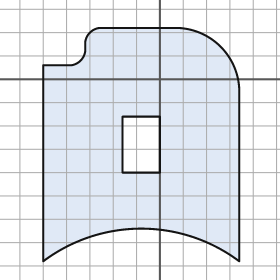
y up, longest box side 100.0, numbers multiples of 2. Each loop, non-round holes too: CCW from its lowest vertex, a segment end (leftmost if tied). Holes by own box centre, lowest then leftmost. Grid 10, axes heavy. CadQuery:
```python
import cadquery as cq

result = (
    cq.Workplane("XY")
    .moveTo(-50.0, -78.0)
    .threePointArc((-8.0, -64.0), (34.0, -78.0))
    .lineTo(34.0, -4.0)
    .threePointArc((26.0, 14.0), (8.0, 22.0))
    .lineTo(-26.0, 22.0)
    .threePointArc((-30.0, 20.0), (-32.0, 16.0))
    .lineTo(-32.0, 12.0)
    .threePointArc((-34.0, 8.0), (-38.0, 6.0))
    .lineTo(-50.0, 6.0)
    .close()
    .moveTo(-16.0, -40.0)
    .lineTo(0.0, -40.0)
    .lineTo(0.0, -16.0)
    .lineTo(-16.0, -16.0)
    .close()
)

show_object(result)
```